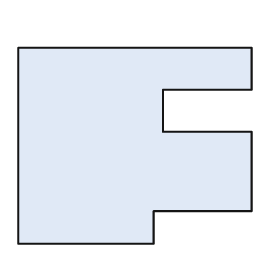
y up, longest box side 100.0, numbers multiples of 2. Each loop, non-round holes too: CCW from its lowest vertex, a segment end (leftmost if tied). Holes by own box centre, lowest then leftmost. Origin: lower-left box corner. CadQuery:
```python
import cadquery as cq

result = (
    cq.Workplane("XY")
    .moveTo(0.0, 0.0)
    .lineTo(58.0, 0.0)
    .lineTo(58.0, 14.0)
    .lineTo(100.0, 14.0)
    .lineTo(100.0, 48.0)
    .lineTo(62.0, 48.0)
    .lineTo(62.0, 66.0)
    .lineTo(100.0, 66.0)
    .lineTo(100.0, 84.0)
    .lineTo(0.0, 84.0)
    .close()
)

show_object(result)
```